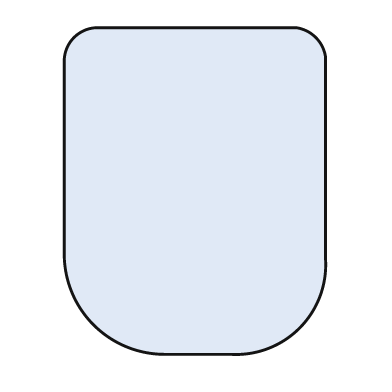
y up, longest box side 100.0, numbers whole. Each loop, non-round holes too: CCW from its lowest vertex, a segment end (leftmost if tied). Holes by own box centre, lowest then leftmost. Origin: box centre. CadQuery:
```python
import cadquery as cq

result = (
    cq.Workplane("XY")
    .moveTo(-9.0, -50.0)
    .lineTo(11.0, -50.0)
    .threePointArc((32.0, -42.0), (40.0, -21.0))
    .lineTo(40.0, 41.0)
    .threePointArc((37.0, 47.0), (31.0, 50.0))
    .lineTo(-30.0, 50.0)
    .threePointArc((-37.0, 47.0), (-40.0, 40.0))
    .lineTo(-40.0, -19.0)
    .threePointArc((-31.0, -41.0), (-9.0, -50.0))
    .close()
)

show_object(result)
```